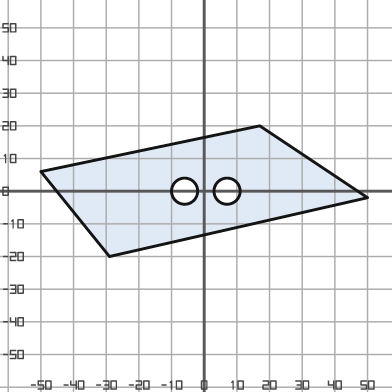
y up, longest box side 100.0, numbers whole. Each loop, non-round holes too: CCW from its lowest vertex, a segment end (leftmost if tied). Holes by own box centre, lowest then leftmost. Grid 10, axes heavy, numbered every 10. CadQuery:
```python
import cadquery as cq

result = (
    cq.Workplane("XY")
    .moveTo(-29.0, -20.0)
    .lineTo(50.0, -2.0)
    .lineTo(17.0, 20.0)
    .lineTo(-50.0, 6.0)
    .close()
    .moveTo(-6.0, 0.0)
    .circle(4.0)
    .moveTo(7.0, 0.0)
    .circle(4.0)
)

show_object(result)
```